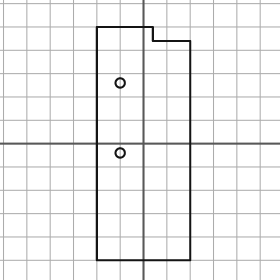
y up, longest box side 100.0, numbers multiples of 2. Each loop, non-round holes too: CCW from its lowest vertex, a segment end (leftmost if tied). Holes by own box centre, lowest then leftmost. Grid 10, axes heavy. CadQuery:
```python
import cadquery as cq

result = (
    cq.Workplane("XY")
    .moveTo(-20.0, -50.0)
    .lineTo(20.0, -50.0)
    .lineTo(20.0, 44.0)
    .lineTo(4.0, 44.0)
    .lineTo(4.0, 50.0)
    .lineTo(-20.0, 50.0)
    .close()
    .moveTo(-10.0, -4.0)
    .circle(2.0)
    .moveTo(-10.0, 26.0)
    .circle(2.0)
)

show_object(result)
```